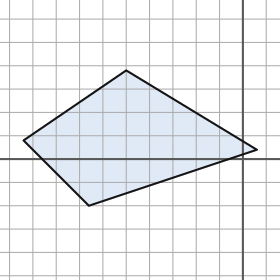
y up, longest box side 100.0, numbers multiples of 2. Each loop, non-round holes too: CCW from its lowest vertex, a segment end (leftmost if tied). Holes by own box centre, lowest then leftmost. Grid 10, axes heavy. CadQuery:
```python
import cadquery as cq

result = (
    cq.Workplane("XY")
    .moveTo(-66.0, -20.0)
    .lineTo(6.0, 4.0)
    .lineTo(-50.0, 38.0)
    .lineTo(-94.0, 8.0)
    .close()
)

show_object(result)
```